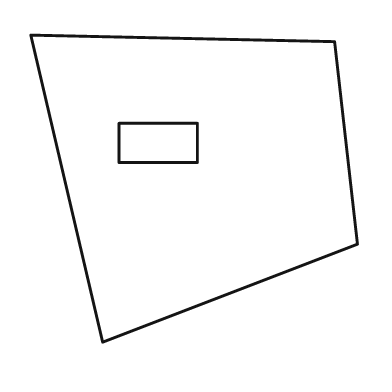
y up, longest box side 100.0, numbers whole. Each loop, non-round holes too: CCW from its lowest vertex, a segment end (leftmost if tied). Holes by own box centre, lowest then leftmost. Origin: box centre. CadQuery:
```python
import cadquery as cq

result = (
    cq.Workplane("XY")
    .moveTo(-28.0, -47.0)
    .lineTo(50.0, -17.0)
    .lineTo(43.0, 45.0)
    .lineTo(-50.0, 47.0)
    .close()
    .moveTo(-23.0, 8.0)
    .lineTo(1.0, 8.0)
    .lineTo(1.0, 20.0)
    .lineTo(-23.0, 20.0)
    .close()
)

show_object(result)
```